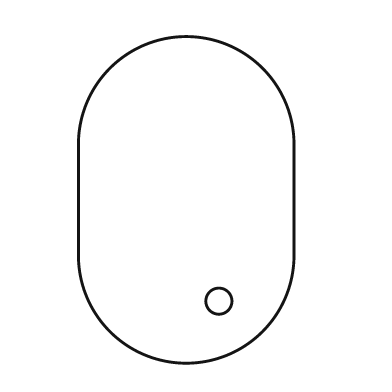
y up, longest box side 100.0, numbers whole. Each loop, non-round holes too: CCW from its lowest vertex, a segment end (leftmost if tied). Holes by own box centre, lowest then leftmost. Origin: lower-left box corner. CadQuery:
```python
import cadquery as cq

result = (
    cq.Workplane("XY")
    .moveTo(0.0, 33.0)
    .threePointArc((33.0, 0.0), (66.0, 33.0))
    .lineTo(66.0, 67.0)
    .threePointArc((33.0, 100.0), (0.0, 67.0))
    .close()
    .moveTo(43.0, 19.0)
    .circle(4.0)
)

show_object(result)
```